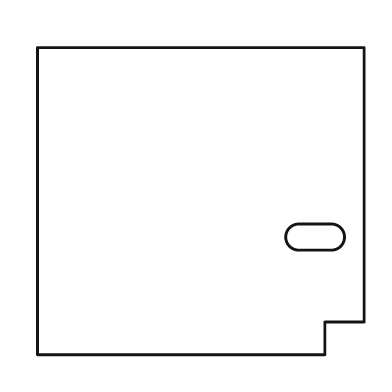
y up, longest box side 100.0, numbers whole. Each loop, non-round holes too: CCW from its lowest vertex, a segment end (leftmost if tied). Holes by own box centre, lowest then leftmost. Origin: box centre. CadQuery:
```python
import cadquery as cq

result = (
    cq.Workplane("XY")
    .moveTo(-50.0, -47.0)
    .lineTo(38.0, -47.0)
    .lineTo(38.0, -37.0)
    .lineTo(50.0, -37.0)
    .lineTo(50.0, 47.0)
    .lineTo(-50.0, 47.0)
    .close()
    .moveTo(30.0, -15.0)
    .lineTo(40.0, -15.0)
    .threePointArc((44.0, -11.0), (40.0, -7.0))
    .lineTo(30.0, -7.0)
    .threePointArc((26.0, -11.0), (30.0, -15.0))
    .close()
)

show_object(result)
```